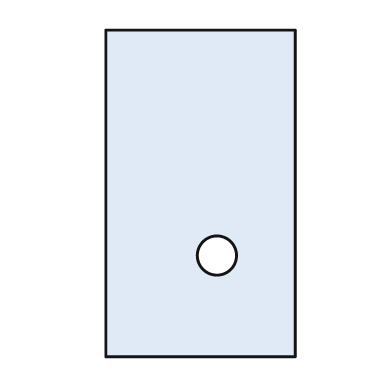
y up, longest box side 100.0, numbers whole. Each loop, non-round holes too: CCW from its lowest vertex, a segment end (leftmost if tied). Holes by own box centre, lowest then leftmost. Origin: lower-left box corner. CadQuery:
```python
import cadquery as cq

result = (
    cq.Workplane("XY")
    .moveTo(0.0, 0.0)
    .lineTo(58.0, 0.0)
    .lineTo(58.0, 100.0)
    .lineTo(0.0, 100.0)
    .close()
    .moveTo(34.0, 31.0)
    .circle(6.0)
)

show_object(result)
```